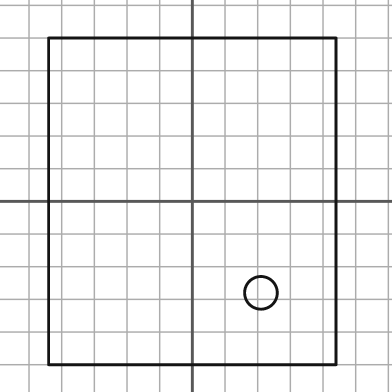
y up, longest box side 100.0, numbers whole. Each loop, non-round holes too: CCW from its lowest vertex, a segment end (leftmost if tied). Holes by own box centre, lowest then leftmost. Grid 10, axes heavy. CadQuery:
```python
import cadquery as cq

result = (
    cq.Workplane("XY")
    .moveTo(-44.0, -50.0)
    .lineTo(44.0, -50.0)
    .lineTo(44.0, 50.0)
    .lineTo(-44.0, 50.0)
    .close()
    .moveTo(21.0, -28.0)
    .circle(5.0)
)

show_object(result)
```